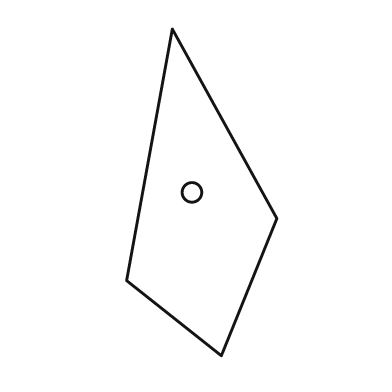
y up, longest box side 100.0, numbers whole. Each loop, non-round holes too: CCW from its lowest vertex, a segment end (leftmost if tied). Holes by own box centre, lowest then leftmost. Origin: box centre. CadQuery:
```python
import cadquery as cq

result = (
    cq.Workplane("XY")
    .moveTo(6.0, -50.0)
    .lineTo(23.0, -8.0)
    .lineTo(-9.0, 50.0)
    .lineTo(-23.0, -27.0)
    .close()
    .moveTo(-3.0, 0.0)
    .circle(3.0)
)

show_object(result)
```